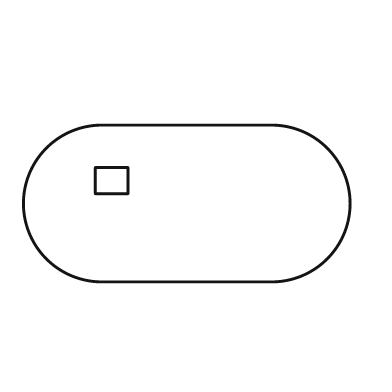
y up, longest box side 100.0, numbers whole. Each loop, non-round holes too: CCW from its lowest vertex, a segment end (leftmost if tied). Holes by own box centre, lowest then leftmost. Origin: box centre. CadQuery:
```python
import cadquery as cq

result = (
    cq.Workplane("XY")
    .moveTo(-26.0, -24.0)
    .lineTo(26.0, -24.0)
    .threePointArc((50.0, 0.0), (26.0, 24.0))
    .lineTo(-26.0, 24.0)
    .threePointArc((-50.0, 0.0), (-26.0, -24.0))
    .close()
    .moveTo(-28.0, 3.0)
    .lineTo(-18.0, 3.0)
    .lineTo(-18.0, 11.0)
    .lineTo(-28.0, 11.0)
    .close()
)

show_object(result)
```